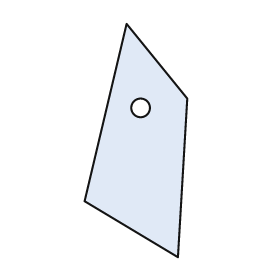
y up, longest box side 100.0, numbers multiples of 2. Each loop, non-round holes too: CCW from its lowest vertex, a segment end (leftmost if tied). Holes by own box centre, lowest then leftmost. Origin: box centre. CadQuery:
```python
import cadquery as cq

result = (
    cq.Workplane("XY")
    .moveTo(18.0, -50.0)
    .lineTo(22.0, 18.0)
    .lineTo(-4.0, 50.0)
    .lineTo(-22.0, -26.0)
    .close()
    .moveTo(2.0, 14.0)
    .circle(4.0)
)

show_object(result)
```